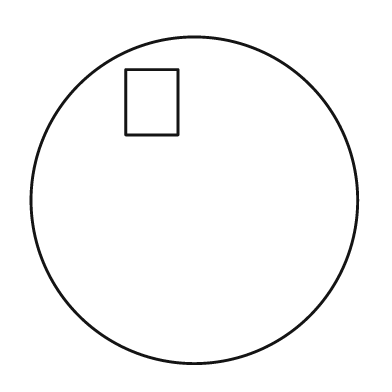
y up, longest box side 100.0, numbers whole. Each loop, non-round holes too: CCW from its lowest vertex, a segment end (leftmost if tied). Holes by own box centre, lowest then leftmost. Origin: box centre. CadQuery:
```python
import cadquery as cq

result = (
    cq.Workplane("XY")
    .moveTo(0.0, 0.0)
    .circle(50.0)
    .moveTo(-21.0, 20.0)
    .lineTo(-5.0, 20.0)
    .lineTo(-5.0, 40.0)
    .lineTo(-21.0, 40.0)
    .close()
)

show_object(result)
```